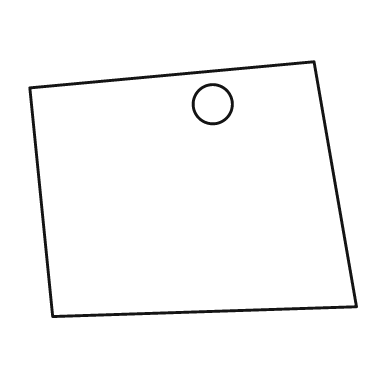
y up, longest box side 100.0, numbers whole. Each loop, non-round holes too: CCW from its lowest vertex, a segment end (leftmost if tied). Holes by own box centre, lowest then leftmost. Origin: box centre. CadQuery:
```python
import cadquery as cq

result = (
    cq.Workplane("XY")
    .moveTo(-43.0, -39.0)
    .lineTo(50.0, -36.0)
    .lineTo(37.0, 39.0)
    .lineTo(-50.0, 31.0)
    .close()
    .moveTo(6.0, 26.0)
    .circle(6.0)
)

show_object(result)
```